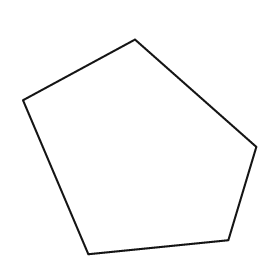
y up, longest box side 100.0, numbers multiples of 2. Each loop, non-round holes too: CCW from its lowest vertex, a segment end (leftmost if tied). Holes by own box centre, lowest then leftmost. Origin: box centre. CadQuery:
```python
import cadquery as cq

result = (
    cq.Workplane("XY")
    .moveTo(-22.0, -46.0)
    .lineTo(38.0, -40.0)
    .lineTo(50.0, 0.0)
    .lineTo(-2.0, 46.0)
    .lineTo(-50.0, 20.0)
    .close()
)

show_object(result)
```